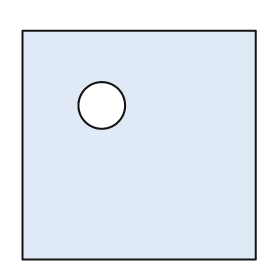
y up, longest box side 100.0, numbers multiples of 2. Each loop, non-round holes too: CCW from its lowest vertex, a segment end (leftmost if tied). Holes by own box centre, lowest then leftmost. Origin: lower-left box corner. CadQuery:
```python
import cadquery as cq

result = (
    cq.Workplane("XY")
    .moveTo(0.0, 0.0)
    .lineTo(100.0, 0.0)
    .lineTo(100.0, 98.0)
    .lineTo(0.0, 98.0)
    .close()
    .moveTo(34.0, 66.0)
    .circle(10.0)
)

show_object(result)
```